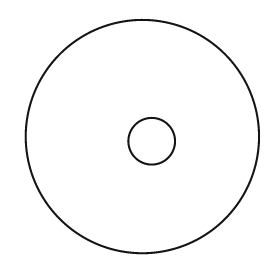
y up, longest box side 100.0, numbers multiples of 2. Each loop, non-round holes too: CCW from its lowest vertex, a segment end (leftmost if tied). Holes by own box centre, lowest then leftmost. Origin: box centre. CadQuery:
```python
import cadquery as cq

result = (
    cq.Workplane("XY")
    .moveTo(0.0, 0.0)
    .circle(50.0)
    .moveTo(4.0, -2.0)
    .circle(10.0)
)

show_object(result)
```